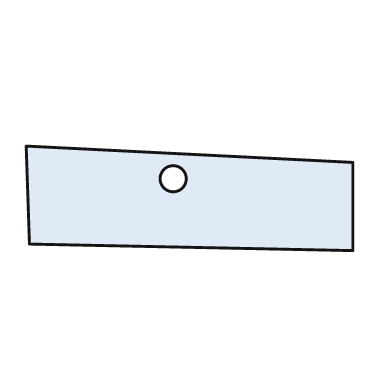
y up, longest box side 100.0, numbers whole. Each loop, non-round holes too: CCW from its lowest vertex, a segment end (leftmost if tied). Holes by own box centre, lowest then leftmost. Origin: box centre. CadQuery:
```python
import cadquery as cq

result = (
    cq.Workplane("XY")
    .moveTo(50.0, -16.0)
    .lineTo(50.0, 11.0)
    .lineTo(-50.0, 16.0)
    .lineTo(-49.0, -14.0)
    .close()
    .moveTo(-5.0, 6.0)
    .circle(4.0)
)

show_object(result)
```